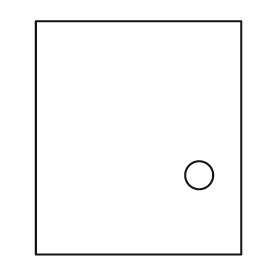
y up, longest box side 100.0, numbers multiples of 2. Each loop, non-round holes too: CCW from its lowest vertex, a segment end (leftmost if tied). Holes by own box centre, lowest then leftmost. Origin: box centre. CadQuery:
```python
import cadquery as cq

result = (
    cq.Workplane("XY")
    .moveTo(-44.0, -50.0)
    .lineTo(44.0, -50.0)
    .lineTo(44.0, 50.0)
    .lineTo(-44.0, 50.0)
    .close()
    .moveTo(26.0, -16.0)
    .circle(6.0)
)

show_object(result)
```